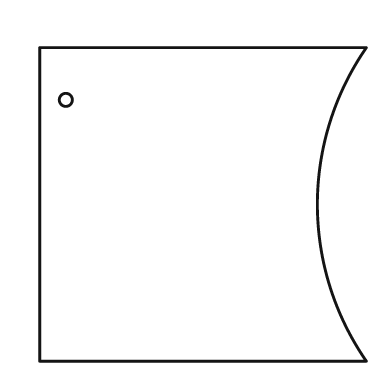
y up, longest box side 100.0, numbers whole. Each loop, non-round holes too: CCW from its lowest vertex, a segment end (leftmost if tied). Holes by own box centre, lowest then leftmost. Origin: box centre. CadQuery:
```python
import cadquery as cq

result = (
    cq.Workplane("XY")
    .moveTo(-50.0, -48.0)
    .lineTo(50.0, -48.0)
    .threePointArc((35.0, 0.0), (50.0, 48.0))
    .lineTo(-50.0, 48.0)
    .close()
    .moveTo(-42.0, 32.0)
    .circle(2.0)
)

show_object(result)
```